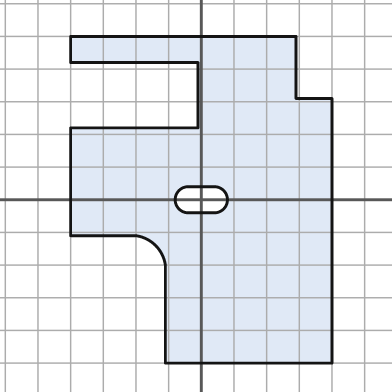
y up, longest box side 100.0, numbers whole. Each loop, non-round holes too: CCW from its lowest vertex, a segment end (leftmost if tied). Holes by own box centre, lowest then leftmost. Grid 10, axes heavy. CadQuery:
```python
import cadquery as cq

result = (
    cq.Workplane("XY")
    .moveTo(-11.0, -50.0)
    .lineTo(40.0, -50.0)
    .lineTo(40.0, 31.0)
    .lineTo(29.0, 31.0)
    .lineTo(29.0, 50.0)
    .lineTo(-40.0, 50.0)
    .lineTo(-40.0, 42.0)
    .lineTo(-1.0, 42.0)
    .lineTo(-1.0, 22.0)
    .lineTo(-40.0, 22.0)
    .lineTo(-40.0, -11.0)
    .lineTo(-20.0, -11.0)
    .threePointArc((-14.0, -14.0), (-11.0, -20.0))
    .close()
    .moveTo(-4.0, -4.0)
    .lineTo(4.0, -4.0)
    .threePointArc((8.0, 0.0), (4.0, 4.0))
    .lineTo(-4.0, 4.0)
    .threePointArc((-8.0, 0.0), (-4.0, -4.0))
    .close()
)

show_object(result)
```